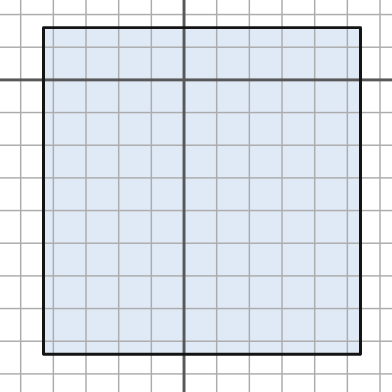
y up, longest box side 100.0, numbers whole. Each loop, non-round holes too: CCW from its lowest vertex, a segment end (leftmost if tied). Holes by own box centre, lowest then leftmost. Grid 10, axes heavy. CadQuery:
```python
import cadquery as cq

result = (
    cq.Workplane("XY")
    .moveTo(-43.0, -84.0)
    .lineTo(54.0, -84.0)
    .lineTo(54.0, 16.0)
    .lineTo(-43.0, 16.0)
    .close()
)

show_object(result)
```